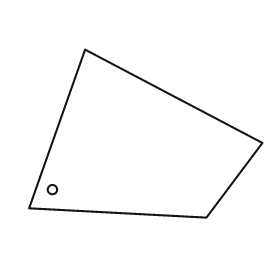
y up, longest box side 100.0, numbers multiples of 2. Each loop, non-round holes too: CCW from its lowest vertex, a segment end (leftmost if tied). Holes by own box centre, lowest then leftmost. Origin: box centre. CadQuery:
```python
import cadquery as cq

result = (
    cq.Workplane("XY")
    .moveTo(26.0, -36.0)
    .lineTo(50.0, -4.0)
    .lineTo(-26.0, 36.0)
    .lineTo(-50.0, -32.0)
    .close()
    .moveTo(-40.0, -24.0)
    .circle(2.0)
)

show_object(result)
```